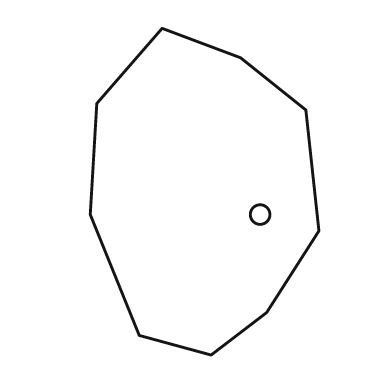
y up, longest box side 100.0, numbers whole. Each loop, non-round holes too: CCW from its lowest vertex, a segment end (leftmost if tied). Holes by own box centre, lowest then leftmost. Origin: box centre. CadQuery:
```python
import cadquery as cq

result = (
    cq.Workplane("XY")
    .moveTo(2.0, -50.0)
    .lineTo(19.0, -37.0)
    .lineTo(35.0, -12.0)
    .lineTo(31.0, 25.0)
    .lineTo(11.0, 41.0)
    .lineTo(-13.0, 50.0)
    .lineTo(-33.0, 27.0)
    .lineTo(-35.0, -7.0)
    .lineTo(-20.0, -44.0)
    .close()
    .moveTo(17.0, -7.0)
    .circle(3.0)
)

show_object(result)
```